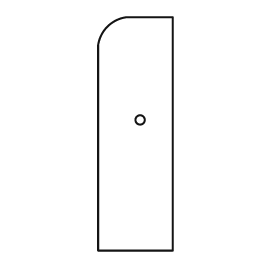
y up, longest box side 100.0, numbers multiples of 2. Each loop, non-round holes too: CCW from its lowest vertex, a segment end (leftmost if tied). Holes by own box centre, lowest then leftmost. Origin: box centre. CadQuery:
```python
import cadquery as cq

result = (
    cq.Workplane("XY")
    .moveTo(-16.0, -50.0)
    .lineTo(16.0, -50.0)
    .lineTo(16.0, 50.0)
    .lineTo(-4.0, 50.0)
    .threePointArc((-12.0, 46.0), (-16.0, 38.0))
    .close()
    .moveTo(2.0, 6.0)
    .circle(2.0)
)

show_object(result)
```